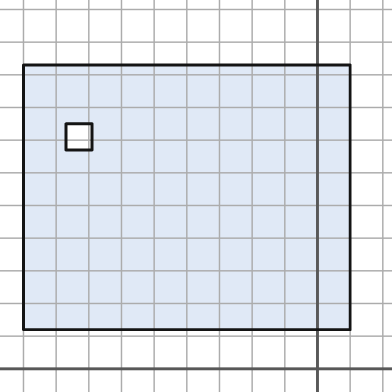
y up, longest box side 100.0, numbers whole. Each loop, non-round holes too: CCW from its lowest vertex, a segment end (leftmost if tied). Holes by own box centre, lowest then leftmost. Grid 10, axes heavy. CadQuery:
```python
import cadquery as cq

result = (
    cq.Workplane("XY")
    .moveTo(-90.0, 12.0)
    .lineTo(10.0, 12.0)
    .lineTo(10.0, 93.0)
    .lineTo(-90.0, 93.0)
    .close()
    .moveTo(-77.0, 67.0)
    .lineTo(-69.0, 67.0)
    .lineTo(-69.0, 75.0)
    .lineTo(-77.0, 75.0)
    .close()
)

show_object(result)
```